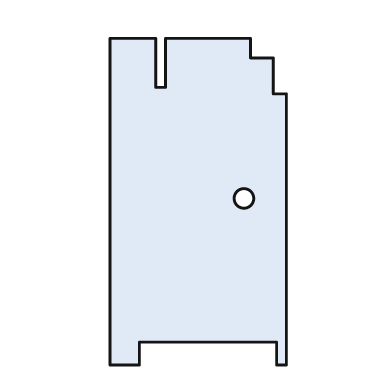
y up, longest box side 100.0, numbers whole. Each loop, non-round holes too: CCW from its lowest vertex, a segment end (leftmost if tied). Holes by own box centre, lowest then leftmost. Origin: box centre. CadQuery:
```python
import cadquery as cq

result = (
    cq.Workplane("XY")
    .moveTo(-27.0, -50.0)
    .lineTo(-18.0, -50.0)
    .lineTo(-18.0, -43.0)
    .lineTo(24.0, -43.0)
    .lineTo(24.0, -50.0)
    .lineTo(27.0, -50.0)
    .lineTo(27.0, 33.0)
    .lineTo(23.0, 33.0)
    .lineTo(23.0, 44.0)
    .lineTo(16.0, 44.0)
    .lineTo(16.0, 50.0)
    .lineTo(-10.0, 50.0)
    .lineTo(-10.0, 35.0)
    .lineTo(-13.0, 35.0)
    .lineTo(-13.0, 50.0)
    .lineTo(-27.0, 50.0)
    .close()
    .moveTo(14.0, 1.0)
    .circle(3.0)
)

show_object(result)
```